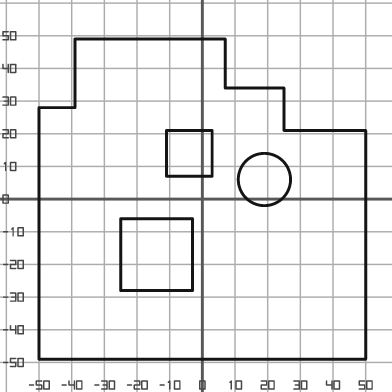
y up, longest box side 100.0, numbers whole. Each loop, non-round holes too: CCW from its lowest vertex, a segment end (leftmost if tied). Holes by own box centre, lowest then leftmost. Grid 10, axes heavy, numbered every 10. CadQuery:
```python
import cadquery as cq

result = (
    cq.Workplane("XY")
    .moveTo(-50.0, -49.0)
    .lineTo(50.0, -49.0)
    .lineTo(50.0, 21.0)
    .lineTo(25.0, 21.0)
    .lineTo(25.0, 34.0)
    .lineTo(7.0, 34.0)
    .lineTo(7.0, 49.0)
    .lineTo(-39.0, 49.0)
    .lineTo(-39.0, 28.0)
    .lineTo(-50.0, 28.0)
    .close()
    .moveTo(-25.0, -28.0)
    .lineTo(-3.0, -28.0)
    .lineTo(-3.0, -6.0)
    .lineTo(-25.0, -6.0)
    .close()
    .moveTo(19.0, 6.0)
    .circle(8.0)
    .moveTo(-11.0, 7.0)
    .lineTo(3.0, 7.0)
    .lineTo(3.0, 21.0)
    .lineTo(-11.0, 21.0)
    .close()
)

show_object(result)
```